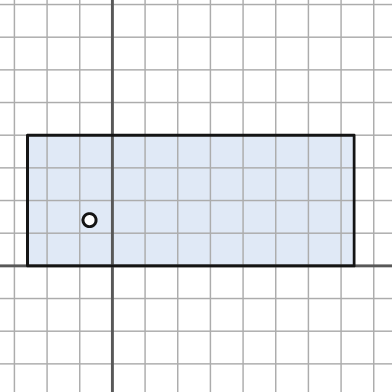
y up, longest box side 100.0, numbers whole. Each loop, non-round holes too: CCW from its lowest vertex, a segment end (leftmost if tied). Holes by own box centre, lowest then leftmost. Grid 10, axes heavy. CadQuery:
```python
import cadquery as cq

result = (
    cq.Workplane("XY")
    .moveTo(-26.0, 0.0)
    .lineTo(74.0, 0.0)
    .lineTo(74.0, 40.0)
    .lineTo(-26.0, 40.0)
    .close()
    .moveTo(-7.0, 14.0)
    .circle(2.0)
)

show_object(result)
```